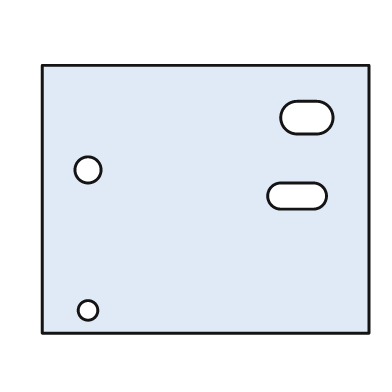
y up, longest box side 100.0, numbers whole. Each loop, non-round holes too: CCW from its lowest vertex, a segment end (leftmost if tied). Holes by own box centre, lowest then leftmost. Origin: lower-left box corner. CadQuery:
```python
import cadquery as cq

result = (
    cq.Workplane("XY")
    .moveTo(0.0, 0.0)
    .lineTo(100.0, 0.0)
    .lineTo(100.0, 82.0)
    .lineTo(0.0, 82.0)
    .close()
    .moveTo(14.0, 7.0)
    .circle(3.0)
    .moveTo(73.0, 38.0)
    .lineTo(83.0, 38.0)
    .threePointArc((87.0, 42.0), (83.0, 46.0))
    .lineTo(73.0, 46.0)
    .threePointArc((69.0, 42.0), (73.0, 38.0))
    .close()
    .moveTo(14.0, 50.0)
    .circle(4.0)
    .moveTo(78.0, 61.0)
    .lineTo(84.0, 61.0)
    .threePointArc((89.0, 66.0), (84.0, 71.0))
    .lineTo(78.0, 71.0)
    .threePointArc((73.0, 66.0), (78.0, 61.0))
    .close()
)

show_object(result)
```